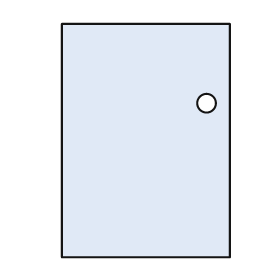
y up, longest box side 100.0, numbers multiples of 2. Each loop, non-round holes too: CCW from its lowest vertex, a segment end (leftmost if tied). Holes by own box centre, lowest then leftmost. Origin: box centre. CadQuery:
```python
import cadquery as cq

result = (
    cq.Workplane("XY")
    .moveTo(-36.0, -50.0)
    .lineTo(36.0, -50.0)
    .lineTo(36.0, 50.0)
    .lineTo(-36.0, 50.0)
    .close()
    .moveTo(26.0, 16.0)
    .circle(4.0)
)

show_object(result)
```